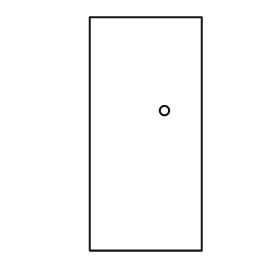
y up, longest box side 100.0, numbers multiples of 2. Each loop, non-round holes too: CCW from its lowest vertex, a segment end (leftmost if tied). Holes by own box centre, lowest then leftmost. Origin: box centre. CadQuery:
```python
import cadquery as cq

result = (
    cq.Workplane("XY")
    .moveTo(-24.0, -50.0)
    .lineTo(24.0, -50.0)
    .lineTo(24.0, 50.0)
    .lineTo(-24.0, 50.0)
    .close()
    .moveTo(8.0, 10.0)
    .circle(2.0)
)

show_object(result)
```